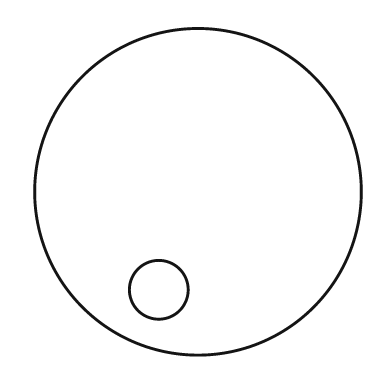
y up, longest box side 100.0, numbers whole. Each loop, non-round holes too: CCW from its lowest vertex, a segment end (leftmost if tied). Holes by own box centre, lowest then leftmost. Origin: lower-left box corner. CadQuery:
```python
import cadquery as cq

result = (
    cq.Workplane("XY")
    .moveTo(50.0, 50.0)
    .circle(50.0)
    .moveTo(38.0, 20.0)
    .circle(9.0)
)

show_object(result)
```